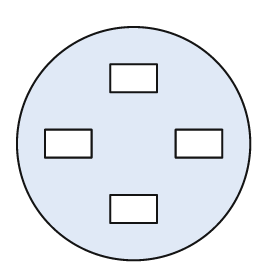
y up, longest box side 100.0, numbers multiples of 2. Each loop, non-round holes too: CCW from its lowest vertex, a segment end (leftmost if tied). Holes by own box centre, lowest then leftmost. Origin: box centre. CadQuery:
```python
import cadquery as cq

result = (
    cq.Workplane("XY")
    .moveTo(0.0, 0.0)
    .circle(50.0)
    .moveTo(-10.0, -34.0)
    .lineTo(10.0, -34.0)
    .lineTo(10.0, -22.0)
    .lineTo(-10.0, -22.0)
    .close()
    .moveTo(-38.0, -6.0)
    .lineTo(-18.0, -6.0)
    .lineTo(-18.0, 6.0)
    .lineTo(-38.0, 6.0)
    .close()
    .moveTo(18.0, -6.0)
    .lineTo(38.0, -6.0)
    .lineTo(38.0, 6.0)
    .lineTo(18.0, 6.0)
    .close()
    .moveTo(-10.0, 22.0)
    .lineTo(10.0, 22.0)
    .lineTo(10.0, 34.0)
    .lineTo(-10.0, 34.0)
    .close()
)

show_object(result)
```